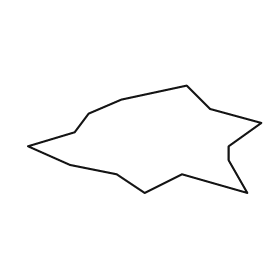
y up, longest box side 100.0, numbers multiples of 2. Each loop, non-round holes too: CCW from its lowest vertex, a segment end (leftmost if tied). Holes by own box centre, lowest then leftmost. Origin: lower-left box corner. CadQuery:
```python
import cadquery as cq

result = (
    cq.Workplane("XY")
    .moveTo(50.0, 0.0)
    .lineTo(66.0, 8.0)
    .lineTo(94.0, 0.0)
    .lineTo(86.0, 14.0)
    .lineTo(86.0, 20.0)
    .lineTo(100.0, 30.0)
    .lineTo(78.0, 36.0)
    .lineTo(68.0, 46.0)
    .lineTo(40.0, 40.0)
    .lineTo(26.0, 34.0)
    .lineTo(20.0, 26.0)
    .lineTo(0.0, 20.0)
    .lineTo(18.0, 12.0)
    .lineTo(38.0, 8.0)
    .close()
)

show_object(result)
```